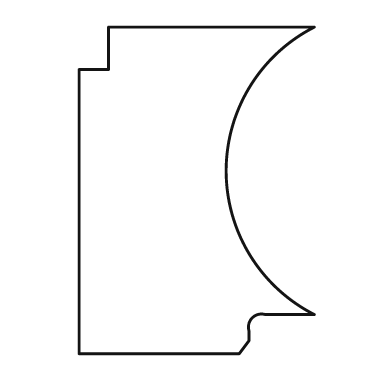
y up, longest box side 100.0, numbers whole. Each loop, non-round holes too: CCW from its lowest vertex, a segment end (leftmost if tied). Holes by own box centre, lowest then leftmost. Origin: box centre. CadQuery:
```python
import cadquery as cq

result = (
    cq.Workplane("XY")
    .moveTo(-36.0, -50.0)
    .lineTo(13.0, -50.0)
    .lineTo(16.0, -46.0)
    .lineTo(16.0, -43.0)
    .threePointArc((17.0, -39.0), (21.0, -38.0))
    .lineTo(36.0, -38.0)
    .threePointArc((9.0, 6.0), (36.0, 50.0))
    .lineTo(-27.0, 50.0)
    .lineTo(-27.0, 37.0)
    .lineTo(-36.0, 37.0)
    .close()
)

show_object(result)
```